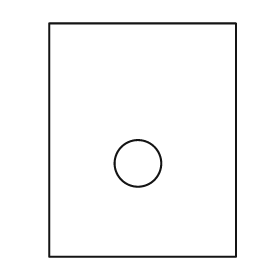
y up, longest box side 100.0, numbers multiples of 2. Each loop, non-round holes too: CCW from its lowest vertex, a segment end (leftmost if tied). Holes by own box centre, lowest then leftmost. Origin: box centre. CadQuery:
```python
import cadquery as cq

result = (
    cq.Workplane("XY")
    .moveTo(-40.0, -50.0)
    .lineTo(40.0, -50.0)
    .lineTo(40.0, 50.0)
    .lineTo(-40.0, 50.0)
    .close()
    .moveTo(-2.0, -10.0)
    .circle(10.0)
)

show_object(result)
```